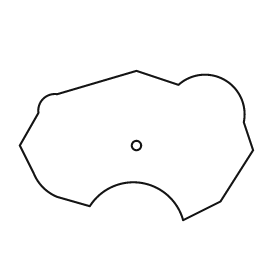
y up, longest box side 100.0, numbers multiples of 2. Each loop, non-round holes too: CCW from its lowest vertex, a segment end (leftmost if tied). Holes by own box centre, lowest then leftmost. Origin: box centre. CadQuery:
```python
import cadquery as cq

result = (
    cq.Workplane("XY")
    .moveTo(20.0, -32.0)
    .lineTo(36.0, -24.0)
    .lineTo(50.0, -2.0)
    .lineTo(46.0, 10.0)
    .threePointArc((38.0, 28.0), (18.0, 26.0))
    .lineTo(0.0, 32.0)
    .lineTo(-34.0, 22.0)
    .threePointArc((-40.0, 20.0), (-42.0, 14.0))
    .lineTo(-50.0, 0.0)
    .lineTo(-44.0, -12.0)
    .threePointArc((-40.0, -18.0), (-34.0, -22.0))
    .lineTo(-20.0, -26.0)
    .threePointArc((2.0, -16.0), (20.0, -32.0))
    .close()
    .moveTo(0.0, 0.0)
    .circle(2.0)
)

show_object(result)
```